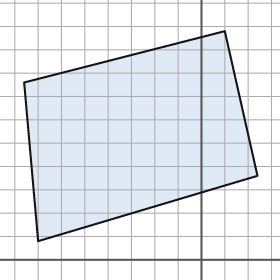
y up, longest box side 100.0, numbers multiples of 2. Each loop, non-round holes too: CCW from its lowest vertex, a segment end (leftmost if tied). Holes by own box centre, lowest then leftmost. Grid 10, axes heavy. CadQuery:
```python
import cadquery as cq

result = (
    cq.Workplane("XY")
    .moveTo(-70.0, 8.0)
    .lineTo(24.0, 36.0)
    .lineTo(10.0, 98.0)
    .lineTo(-76.0, 76.0)
    .close()
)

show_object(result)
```